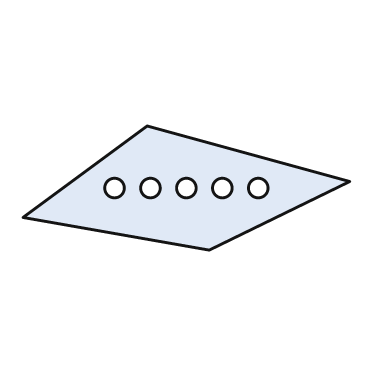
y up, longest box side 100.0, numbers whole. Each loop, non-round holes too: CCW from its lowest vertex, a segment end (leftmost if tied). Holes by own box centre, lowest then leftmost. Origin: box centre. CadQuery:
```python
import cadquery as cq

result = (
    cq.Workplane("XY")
    .moveTo(7.0, -19.0)
    .lineTo(50.0, 2.0)
    .lineTo(-12.0, 19.0)
    .lineTo(-50.0, -9.0)
    .close()
    .moveTo(-22.0, 0.0)
    .circle(3.0)
    .moveTo(-11.0, 0.0)
    .circle(3.0)
    .moveTo(0.0, 0.0)
    .circle(3.0)
    .moveTo(11.0, 0.0)
    .circle(3.0)
    .moveTo(22.0, 0.0)
    .circle(3.0)
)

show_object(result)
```